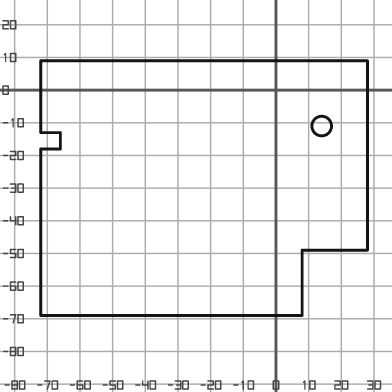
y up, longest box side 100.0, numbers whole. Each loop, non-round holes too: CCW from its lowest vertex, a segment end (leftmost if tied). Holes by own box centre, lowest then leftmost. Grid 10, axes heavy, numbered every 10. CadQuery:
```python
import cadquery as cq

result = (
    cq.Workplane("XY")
    .moveTo(-72.0, -69.0)
    .lineTo(8.0, -69.0)
    .lineTo(8.0, -49.0)
    .lineTo(28.0, -49.0)
    .lineTo(28.0, 9.0)
    .lineTo(-72.0, 9.0)
    .lineTo(-72.0, -13.0)
    .lineTo(-66.0, -13.0)
    .lineTo(-66.0, -18.0)
    .lineTo(-72.0, -18.0)
    .close()
    .moveTo(14.0, -11.0)
    .circle(3.0)
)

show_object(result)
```